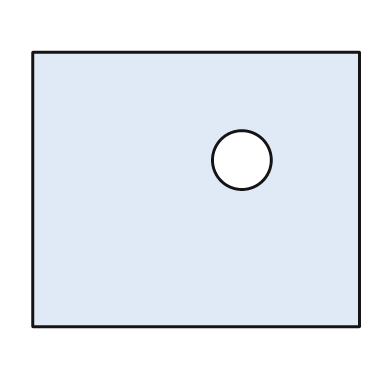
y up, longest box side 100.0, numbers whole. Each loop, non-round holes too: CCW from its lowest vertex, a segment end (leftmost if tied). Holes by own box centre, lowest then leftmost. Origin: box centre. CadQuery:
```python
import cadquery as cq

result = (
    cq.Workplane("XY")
    .moveTo(-50.0, -42.0)
    .lineTo(50.0, -42.0)
    .lineTo(50.0, 42.0)
    .lineTo(-50.0, 42.0)
    .close()
    .moveTo(14.0, 9.0)
    .circle(9.0)
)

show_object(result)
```